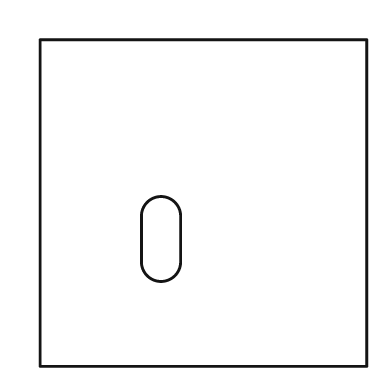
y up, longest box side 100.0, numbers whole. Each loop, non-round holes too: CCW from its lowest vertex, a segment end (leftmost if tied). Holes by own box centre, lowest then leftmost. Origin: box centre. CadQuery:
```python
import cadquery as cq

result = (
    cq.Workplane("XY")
    .moveTo(-50.0, -50.0)
    .lineTo(50.0, -50.0)
    .lineTo(50.0, 50.0)
    .lineTo(-50.0, 50.0)
    .close()
    .moveTo(-19.0, -18.0)
    .threePointArc((-13.0, -24.0), (-7.0, -18.0))
    .lineTo(-7.0, -4.0)
    .threePointArc((-13.0, 2.0), (-19.0, -4.0))
    .close()
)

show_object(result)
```